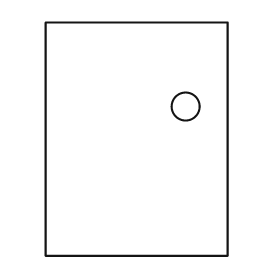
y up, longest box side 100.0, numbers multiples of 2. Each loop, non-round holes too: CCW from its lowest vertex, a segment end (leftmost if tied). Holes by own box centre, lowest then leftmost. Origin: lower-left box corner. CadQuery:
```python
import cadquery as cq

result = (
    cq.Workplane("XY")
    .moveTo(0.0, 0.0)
    .lineTo(78.0, 0.0)
    .lineTo(78.0, 100.0)
    .lineTo(0.0, 100.0)
    .close()
    .moveTo(60.0, 64.0)
    .circle(6.0)
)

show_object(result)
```